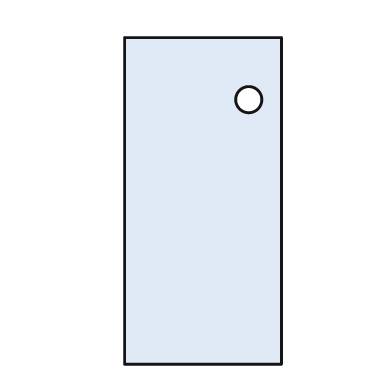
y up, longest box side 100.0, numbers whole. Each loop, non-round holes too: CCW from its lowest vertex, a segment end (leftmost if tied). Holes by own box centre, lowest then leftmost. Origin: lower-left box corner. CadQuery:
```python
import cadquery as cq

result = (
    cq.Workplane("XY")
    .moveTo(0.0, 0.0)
    .lineTo(48.0, 0.0)
    .lineTo(48.0, 100.0)
    .lineTo(0.0, 100.0)
    .close()
    .moveTo(38.0, 81.0)
    .circle(4.0)
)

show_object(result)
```